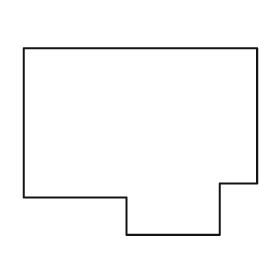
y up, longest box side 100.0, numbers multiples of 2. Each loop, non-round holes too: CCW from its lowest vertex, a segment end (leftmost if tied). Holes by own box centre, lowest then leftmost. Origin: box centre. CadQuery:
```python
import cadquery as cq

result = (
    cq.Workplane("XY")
    .moveTo(-6.0, -40.0)
    .lineTo(34.0, -40.0)
    .lineTo(34.0, -18.0)
    .lineTo(50.0, -18.0)
    .lineTo(50.0, 40.0)
    .lineTo(-50.0, 40.0)
    .lineTo(-50.0, -24.0)
    .lineTo(-6.0, -24.0)
    .close()
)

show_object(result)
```